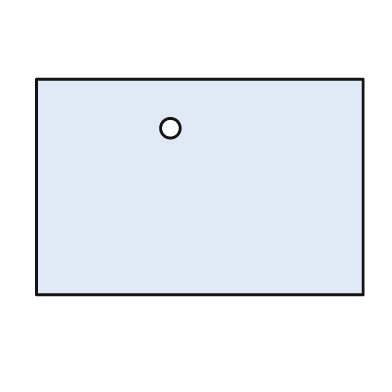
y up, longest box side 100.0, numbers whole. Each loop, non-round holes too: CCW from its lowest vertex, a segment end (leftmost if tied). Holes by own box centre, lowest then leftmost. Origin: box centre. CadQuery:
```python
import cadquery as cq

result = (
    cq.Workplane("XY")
    .moveTo(-50.0, -33.0)
    .lineTo(50.0, -33.0)
    .lineTo(50.0, 33.0)
    .lineTo(-50.0, 33.0)
    .close()
    .moveTo(-9.0, 18.0)
    .circle(3.0)
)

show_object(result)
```